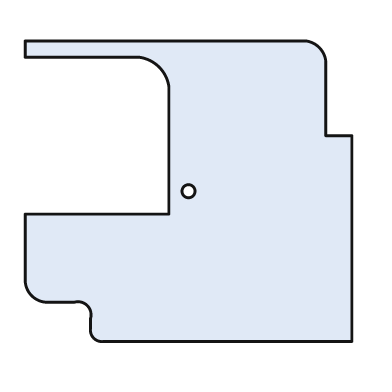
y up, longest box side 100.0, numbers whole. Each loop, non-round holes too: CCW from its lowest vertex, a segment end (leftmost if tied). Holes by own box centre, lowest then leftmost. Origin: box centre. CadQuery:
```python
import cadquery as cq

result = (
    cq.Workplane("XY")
    .moveTo(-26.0, -46.0)
    .lineTo(50.0, -46.0)
    .lineTo(50.0, 17.0)
    .lineTo(42.0, 17.0)
    .lineTo(42.0, 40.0)
    .threePointArc((40.0, 44.0), (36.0, 46.0))
    .lineTo(-50.0, 46.0)
    .lineTo(-50.0, 41.0)
    .lineTo(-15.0, 41.0)
    .threePointArc((-9.0, 38.0), (-6.0, 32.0))
    .lineTo(-6.0, -7.0)
    .lineTo(-50.0, -7.0)
    .lineTo(-50.0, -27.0)
    .threePointArc((-48.0, -32.0), (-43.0, -34.0))
    .lineTo(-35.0, -34.0)
    .threePointArc((-31.0, -35.0), (-30.0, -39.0))
    .lineTo(-30.0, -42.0)
    .threePointArc((-29.0, -45.0), (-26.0, -46.0))
    .close()
    .moveTo(0.0, 0.0)
    .circle(2.0)
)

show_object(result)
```